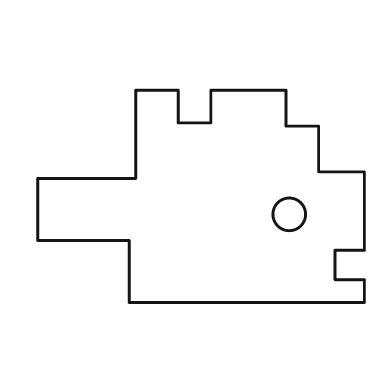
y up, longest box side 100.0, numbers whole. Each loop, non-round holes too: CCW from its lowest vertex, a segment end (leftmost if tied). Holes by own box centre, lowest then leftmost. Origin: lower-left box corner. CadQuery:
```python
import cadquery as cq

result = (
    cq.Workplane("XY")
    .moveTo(28.0, 0.0)
    .lineTo(100.0, 0.0)
    .lineTo(100.0, 7.0)
    .lineTo(91.0, 7.0)
    .lineTo(91.0, 16.0)
    .lineTo(100.0, 16.0)
    .lineTo(100.0, 40.0)
    .lineTo(86.0, 40.0)
    .lineTo(86.0, 54.0)
    .lineTo(76.0, 54.0)
    .lineTo(76.0, 65.0)
    .lineTo(53.0, 65.0)
    .lineTo(53.0, 55.0)
    .lineTo(43.0, 55.0)
    .lineTo(43.0, 65.0)
    .lineTo(30.0, 65.0)
    .lineTo(30.0, 38.0)
    .lineTo(0.0, 38.0)
    .lineTo(0.0, 19.0)
    .lineTo(28.0, 19.0)
    .close()
    .moveTo(77.0, 27.0)
    .circle(5.0)
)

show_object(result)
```